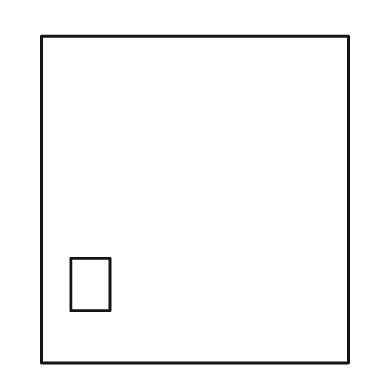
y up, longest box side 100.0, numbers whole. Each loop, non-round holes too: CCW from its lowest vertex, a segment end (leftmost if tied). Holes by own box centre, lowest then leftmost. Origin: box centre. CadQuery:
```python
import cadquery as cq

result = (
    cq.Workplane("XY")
    .moveTo(-47.0, -50.0)
    .lineTo(47.0, -50.0)
    .lineTo(47.0, 50.0)
    .lineTo(-47.0, 50.0)
    .close()
    .moveTo(-38.0, -34.0)
    .lineTo(-26.0, -34.0)
    .lineTo(-26.0, -18.0)
    .lineTo(-38.0, -18.0)
    .close()
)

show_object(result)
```